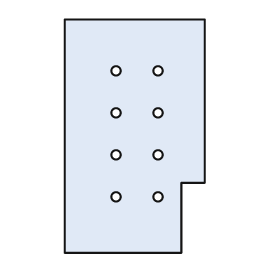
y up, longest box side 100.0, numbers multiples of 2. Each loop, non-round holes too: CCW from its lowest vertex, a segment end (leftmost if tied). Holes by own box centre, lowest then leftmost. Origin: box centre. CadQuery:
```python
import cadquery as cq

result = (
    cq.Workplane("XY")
    .moveTo(-30.0, -50.0)
    .lineTo(20.0, -50.0)
    .lineTo(20.0, -20.0)
    .lineTo(30.0, -20.0)
    .lineTo(30.0, 50.0)
    .lineTo(-30.0, 50.0)
    .close()
    .moveTo(-8.0, -26.0)
    .circle(2.0)
    .moveTo(10.0, -26.0)
    .circle(2.0)
    .moveTo(-8.0, -8.0)
    .circle(2.0)
    .moveTo(10.0, -8.0)
    .circle(2.0)
    .moveTo(-8.0, 10.0)
    .circle(2.0)
    .moveTo(10.0, 10.0)
    .circle(2.0)
    .moveTo(-8.0, 28.0)
    .circle(2.0)
    .moveTo(10.0, 28.0)
    .circle(2.0)
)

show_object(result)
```